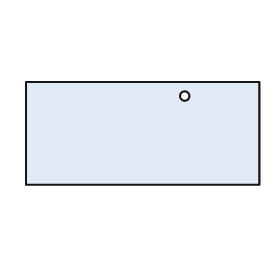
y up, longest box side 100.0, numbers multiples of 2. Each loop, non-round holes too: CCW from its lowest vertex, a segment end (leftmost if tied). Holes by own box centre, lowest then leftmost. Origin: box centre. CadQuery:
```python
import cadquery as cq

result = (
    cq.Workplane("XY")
    .moveTo(-50.0, -22.0)
    .lineTo(50.0, -22.0)
    .lineTo(50.0, 22.0)
    .lineTo(-50.0, 22.0)
    .close()
    .moveTo(18.0, 16.0)
    .circle(2.0)
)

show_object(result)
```